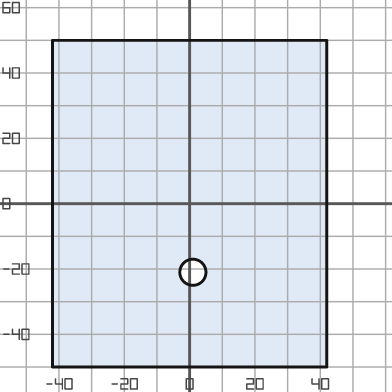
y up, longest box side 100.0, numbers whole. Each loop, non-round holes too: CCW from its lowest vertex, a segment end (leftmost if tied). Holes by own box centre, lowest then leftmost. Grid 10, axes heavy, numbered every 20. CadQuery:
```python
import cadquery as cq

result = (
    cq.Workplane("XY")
    .moveTo(-42.0, -50.0)
    .lineTo(42.0, -50.0)
    .lineTo(42.0, 50.0)
    .lineTo(-42.0, 50.0)
    .close()
    .moveTo(1.0, -21.0)
    .circle(4.0)
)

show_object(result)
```